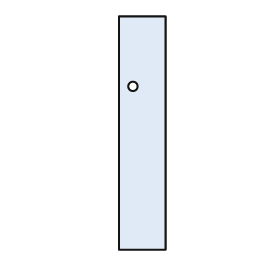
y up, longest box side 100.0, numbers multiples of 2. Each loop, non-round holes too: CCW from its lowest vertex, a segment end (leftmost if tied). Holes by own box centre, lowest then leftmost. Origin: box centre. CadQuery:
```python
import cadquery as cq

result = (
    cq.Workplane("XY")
    .moveTo(-10.0, -50.0)
    .lineTo(10.0, -50.0)
    .lineTo(10.0, 50.0)
    .lineTo(-10.0, 50.0)
    .close()
    .moveTo(-4.0, 20.0)
    .circle(2.0)
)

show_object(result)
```